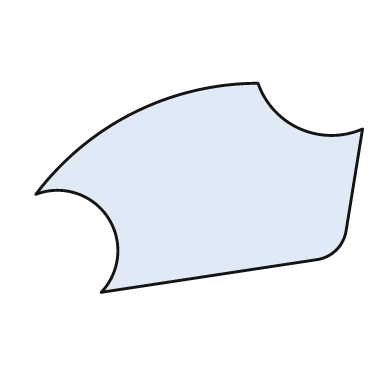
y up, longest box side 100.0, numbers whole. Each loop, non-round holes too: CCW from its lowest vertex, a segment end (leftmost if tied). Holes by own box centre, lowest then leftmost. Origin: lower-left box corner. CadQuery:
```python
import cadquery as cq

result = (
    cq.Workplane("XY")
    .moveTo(20.0, 0.0)
    .lineTo(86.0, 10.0)
    .threePointArc((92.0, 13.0), (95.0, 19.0))
    .lineTo(100.0, 50.0)
    .threePointArc((81.0, 50.0), (68.0, 64.0))
    .threePointArc((30.0, 55.0), (0.0, 30.0))
    .threePointArc((22.0, 23.0), (20.0, 0.0))
    .close()
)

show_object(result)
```